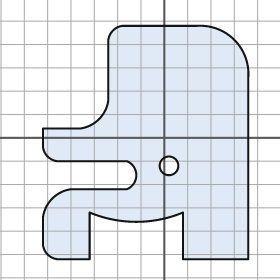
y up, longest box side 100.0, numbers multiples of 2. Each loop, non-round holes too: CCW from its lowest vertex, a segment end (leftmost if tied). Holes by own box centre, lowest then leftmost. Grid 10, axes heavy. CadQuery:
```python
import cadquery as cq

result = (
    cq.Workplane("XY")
    .moveTo(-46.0, -52.0)
    .lineTo(-32.0, -52.0)
    .lineTo(-32.0, -32.0)
    .threePointArc((-12.0, -36.0), (8.0, -32.0))
    .lineTo(8.0, -52.0)
    .lineTo(36.0, -52.0)
    .lineTo(36.0, 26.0)
    .threePointArc((30.0, 42.0), (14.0, 48.0))
    .lineTo(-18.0, 48.0)
    .threePointArc((-22.0, 46.0), (-24.0, 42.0))
    .lineTo(-24.0, 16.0)
    .threePointArc((-28.0, 8.0), (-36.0, 4.0))
    .lineTo(-52.0, 4.0)
    .lineTo(-52.0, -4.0)
    .threePointArc((-50.0, -8.0), (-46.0, -10.0))
    .lineTo(-16.0, -10.0)
    .threePointArc((-12.0, -16.0), (-16.0, -22.0))
    .lineTo(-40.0, -22.0)
    .threePointArc((-48.0, -26.0), (-52.0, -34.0))
    .lineTo(-52.0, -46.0)
    .threePointArc((-50.0, -50.0), (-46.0, -52.0))
    .close()
    .moveTo(2.0, -12.0)
    .circle(4.0)
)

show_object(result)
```